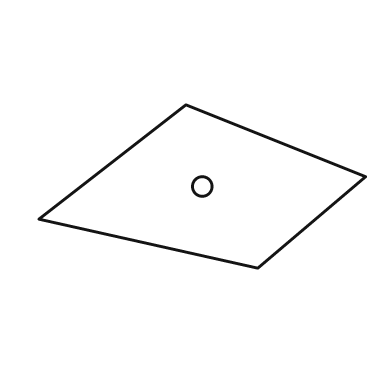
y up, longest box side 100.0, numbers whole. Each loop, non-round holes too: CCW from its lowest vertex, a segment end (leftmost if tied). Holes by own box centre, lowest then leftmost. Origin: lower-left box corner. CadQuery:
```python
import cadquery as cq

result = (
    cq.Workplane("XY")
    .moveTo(67.0, 0.0)
    .lineTo(100.0, 28.0)
    .lineTo(45.0, 50.0)
    .lineTo(0.0, 15.0)
    .close()
    .moveTo(50.0, 25.0)
    .circle(3.0)
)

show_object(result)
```